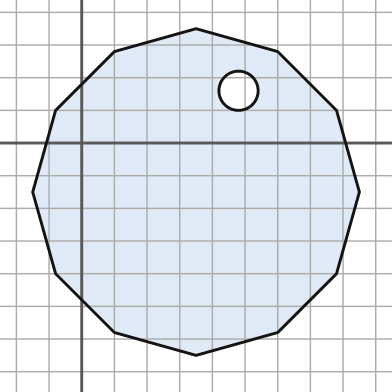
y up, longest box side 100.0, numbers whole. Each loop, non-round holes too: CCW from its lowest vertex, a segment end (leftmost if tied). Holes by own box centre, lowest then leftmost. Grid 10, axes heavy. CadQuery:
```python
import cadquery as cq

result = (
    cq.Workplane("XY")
    .moveTo(35.0, -65.0)
    .lineTo(60.0, -58.0)
    .lineTo(78.0, -40.0)
    .lineTo(85.0, -15.0)
    .lineTo(78.0, 10.0)
    .lineTo(60.0, 28.0)
    .lineTo(35.0, 35.0)
    .lineTo(10.0, 28.0)
    .lineTo(-8.0, 10.0)
    .lineTo(-15.0, -15.0)
    .lineTo(-8.0, -40.0)
    .lineTo(10.0, -58.0)
    .close()
    .moveTo(48.0, 16.0)
    .circle(6.0)
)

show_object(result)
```